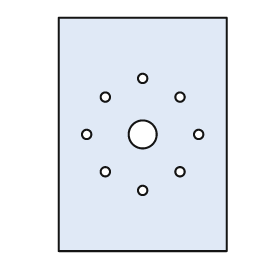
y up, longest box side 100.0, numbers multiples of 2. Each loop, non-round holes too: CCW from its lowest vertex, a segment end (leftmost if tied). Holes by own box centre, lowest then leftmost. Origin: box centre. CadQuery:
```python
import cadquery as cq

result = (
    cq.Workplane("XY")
    .moveTo(-36.0, -50.0)
    .lineTo(36.0, -50.0)
    .lineTo(36.0, 50.0)
    .lineTo(-36.0, 50.0)
    .close()
    .moveTo(0.0, -24.0)
    .circle(2.0)
    .moveTo(-16.0, -16.0)
    .circle(2.0)
    .moveTo(16.0, -16.0)
    .circle(2.0)
    .moveTo(-24.0, 0.0)
    .circle(2.0)
    .moveTo(0.0, 0.0)
    .circle(6.0)
    .moveTo(24.0, 0.0)
    .circle(2.0)
    .moveTo(-16.0, 16.0)
    .circle(2.0)
    .moveTo(16.0, 16.0)
    .circle(2.0)
    .moveTo(0.0, 24.0)
    .circle(2.0)
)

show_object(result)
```